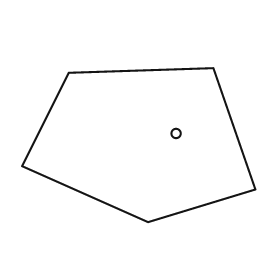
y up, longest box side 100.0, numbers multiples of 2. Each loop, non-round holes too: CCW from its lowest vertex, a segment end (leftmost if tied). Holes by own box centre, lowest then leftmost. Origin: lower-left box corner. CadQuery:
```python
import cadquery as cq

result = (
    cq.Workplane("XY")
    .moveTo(54.0, 0.0)
    .lineTo(100.0, 14.0)
    .lineTo(82.0, 66.0)
    .lineTo(20.0, 64.0)
    .lineTo(0.0, 24.0)
    .close()
    .moveTo(66.0, 38.0)
    .circle(2.0)
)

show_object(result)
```